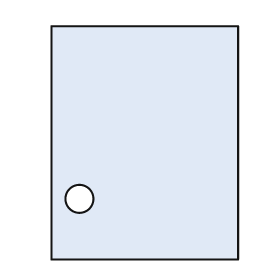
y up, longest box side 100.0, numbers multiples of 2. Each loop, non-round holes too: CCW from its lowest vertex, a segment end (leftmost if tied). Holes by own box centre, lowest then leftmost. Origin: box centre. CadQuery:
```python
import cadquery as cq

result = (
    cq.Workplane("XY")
    .moveTo(-40.0, -50.0)
    .lineTo(40.0, -50.0)
    .lineTo(40.0, 50.0)
    .lineTo(-40.0, 50.0)
    .close()
    .moveTo(-28.0, -24.0)
    .circle(6.0)
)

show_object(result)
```